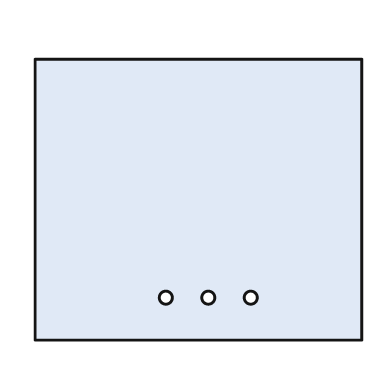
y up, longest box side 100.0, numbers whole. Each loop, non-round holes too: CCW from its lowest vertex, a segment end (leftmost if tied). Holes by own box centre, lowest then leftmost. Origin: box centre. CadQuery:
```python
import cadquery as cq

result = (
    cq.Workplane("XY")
    .moveTo(-50.0, -43.0)
    .lineTo(50.0, -43.0)
    .lineTo(50.0, 43.0)
    .lineTo(-50.0, 43.0)
    .close()
    .moveTo(-10.0, -30.0)
    .circle(2.0)
    .moveTo(3.0, -30.0)
    .circle(2.0)
    .moveTo(16.0, -30.0)
    .circle(2.0)
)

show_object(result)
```